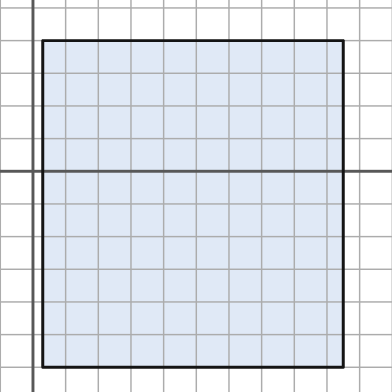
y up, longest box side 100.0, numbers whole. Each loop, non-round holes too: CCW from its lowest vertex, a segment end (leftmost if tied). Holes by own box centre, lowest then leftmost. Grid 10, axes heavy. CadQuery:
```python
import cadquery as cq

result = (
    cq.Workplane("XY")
    .moveTo(3.0, -60.0)
    .lineTo(95.0, -60.0)
    .lineTo(95.0, 40.0)
    .lineTo(3.0, 40.0)
    .close()
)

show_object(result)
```